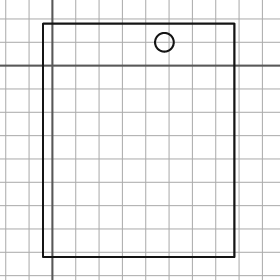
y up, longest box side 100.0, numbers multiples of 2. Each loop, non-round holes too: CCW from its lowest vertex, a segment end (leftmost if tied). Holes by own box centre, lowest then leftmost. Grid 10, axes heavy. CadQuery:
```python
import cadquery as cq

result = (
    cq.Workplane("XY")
    .moveTo(-4.0, -82.0)
    .lineTo(78.0, -82.0)
    .lineTo(78.0, 18.0)
    .lineTo(-4.0, 18.0)
    .close()
    .moveTo(48.0, 10.0)
    .circle(4.0)
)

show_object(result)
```